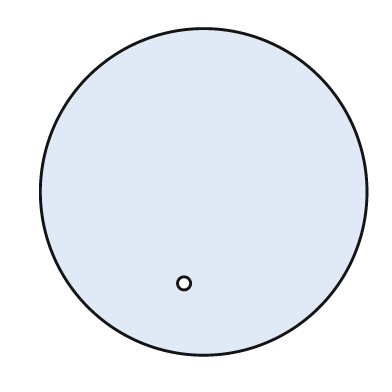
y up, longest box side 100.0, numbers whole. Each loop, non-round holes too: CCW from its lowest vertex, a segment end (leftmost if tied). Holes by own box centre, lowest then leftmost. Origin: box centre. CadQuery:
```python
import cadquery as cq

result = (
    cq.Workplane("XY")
    .moveTo(0.0, 0.0)
    .circle(50.0)
    .moveTo(-6.0, -28.0)
    .circle(2.0)
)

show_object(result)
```